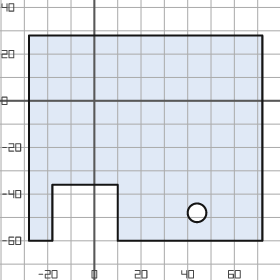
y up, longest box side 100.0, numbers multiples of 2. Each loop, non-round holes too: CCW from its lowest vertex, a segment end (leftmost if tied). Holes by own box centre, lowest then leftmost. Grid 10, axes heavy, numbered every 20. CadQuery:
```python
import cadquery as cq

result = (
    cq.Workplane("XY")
    .moveTo(-28.0, -60.0)
    .lineTo(-18.0, -60.0)
    .lineTo(-18.0, -36.0)
    .lineTo(10.0, -36.0)
    .lineTo(10.0, -60.0)
    .lineTo(72.0, -60.0)
    .lineTo(72.0, 28.0)
    .lineTo(-28.0, 28.0)
    .close()
    .moveTo(44.0, -48.0)
    .circle(4.0)
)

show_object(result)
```